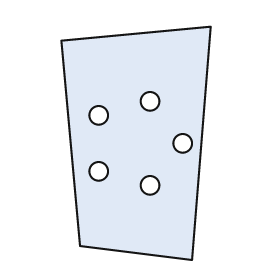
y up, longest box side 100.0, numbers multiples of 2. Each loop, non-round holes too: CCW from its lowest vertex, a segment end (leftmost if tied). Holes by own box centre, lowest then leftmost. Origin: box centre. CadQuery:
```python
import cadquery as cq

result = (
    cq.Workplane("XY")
    .moveTo(24.0, -50.0)
    .lineTo(32.0, 50.0)
    .lineTo(-32.0, 44.0)
    .lineTo(-24.0, -44.0)
    .close()
    .moveTo(6.0, -18.0)
    .circle(4.0)
    .moveTo(-16.0, -12.0)
    .circle(4.0)
    .moveTo(20.0, 0.0)
    .circle(4.0)
    .moveTo(-16.0, 12.0)
    .circle(4.0)
    .moveTo(6.0, 18.0)
    .circle(4.0)
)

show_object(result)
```